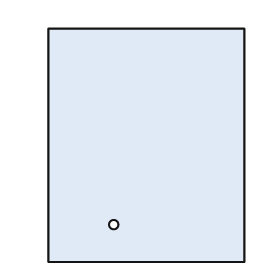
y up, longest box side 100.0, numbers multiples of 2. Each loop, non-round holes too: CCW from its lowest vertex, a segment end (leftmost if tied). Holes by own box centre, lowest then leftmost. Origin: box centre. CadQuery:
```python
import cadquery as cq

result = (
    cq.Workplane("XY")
    .moveTo(-42.0, -50.0)
    .lineTo(42.0, -50.0)
    .lineTo(42.0, 50.0)
    .lineTo(-42.0, 50.0)
    .close()
    .moveTo(-14.0, -34.0)
    .circle(2.0)
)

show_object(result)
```